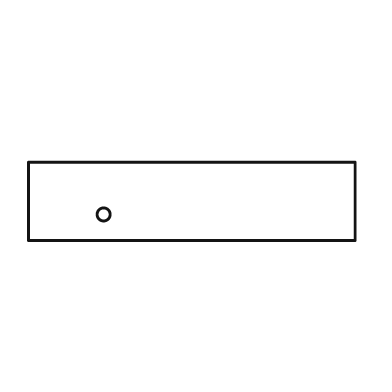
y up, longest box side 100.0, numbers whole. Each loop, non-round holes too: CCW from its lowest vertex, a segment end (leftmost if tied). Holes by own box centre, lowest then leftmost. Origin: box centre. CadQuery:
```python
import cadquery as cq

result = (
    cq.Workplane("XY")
    .moveTo(-50.0, -12.0)
    .lineTo(50.0, -12.0)
    .lineTo(50.0, 12.0)
    .lineTo(-50.0, 12.0)
    .close()
    .moveTo(-27.0, -4.0)
    .circle(2.0)
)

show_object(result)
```